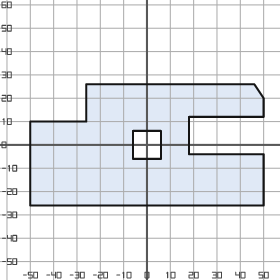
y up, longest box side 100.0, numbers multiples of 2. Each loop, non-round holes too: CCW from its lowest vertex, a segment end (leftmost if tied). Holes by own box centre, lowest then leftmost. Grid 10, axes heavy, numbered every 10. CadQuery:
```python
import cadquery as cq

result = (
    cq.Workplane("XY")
    .moveTo(-50.0, -26.0)
    .lineTo(50.0, -26.0)
    .lineTo(50.0, -4.0)
    .lineTo(18.0, -4.0)
    .lineTo(18.0, 12.0)
    .lineTo(50.0, 12.0)
    .lineTo(50.0, 20.0)
    .lineTo(46.0, 26.0)
    .lineTo(-26.0, 26.0)
    .lineTo(-26.0, 10.0)
    .lineTo(-50.0, 10.0)
    .close()
    .moveTo(-6.0, -6.0)
    .lineTo(6.0, -6.0)
    .lineTo(6.0, 6.0)
    .lineTo(-6.0, 6.0)
    .close()
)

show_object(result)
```